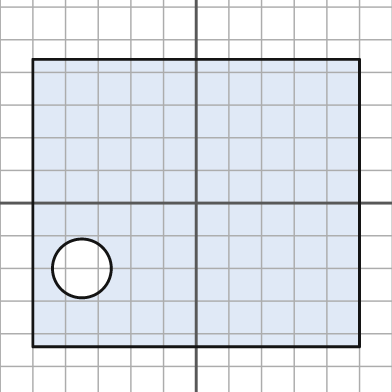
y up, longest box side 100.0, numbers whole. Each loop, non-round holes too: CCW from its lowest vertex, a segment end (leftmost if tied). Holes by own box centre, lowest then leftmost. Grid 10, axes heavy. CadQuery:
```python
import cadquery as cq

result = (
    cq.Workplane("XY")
    .moveTo(-50.0, -44.0)
    .lineTo(50.0, -44.0)
    .lineTo(50.0, 44.0)
    .lineTo(-50.0, 44.0)
    .close()
    .moveTo(-35.0, -20.0)
    .circle(9.0)
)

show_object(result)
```